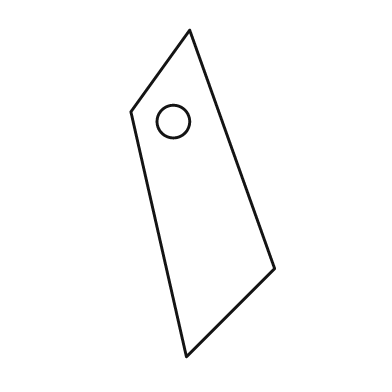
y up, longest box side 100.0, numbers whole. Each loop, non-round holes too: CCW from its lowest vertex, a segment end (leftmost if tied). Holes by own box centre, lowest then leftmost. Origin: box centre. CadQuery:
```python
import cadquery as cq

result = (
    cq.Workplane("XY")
    .moveTo(-5.0, -50.0)
    .lineTo(22.0, -23.0)
    .lineTo(-4.0, 50.0)
    .lineTo(-22.0, 25.0)
    .close()
    .moveTo(-9.0, 22.0)
    .circle(5.0)
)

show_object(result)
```